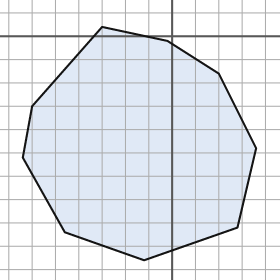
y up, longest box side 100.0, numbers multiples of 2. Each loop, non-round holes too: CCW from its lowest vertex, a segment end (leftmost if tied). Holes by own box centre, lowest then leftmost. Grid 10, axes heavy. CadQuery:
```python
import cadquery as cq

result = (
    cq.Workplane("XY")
    .moveTo(-12.0, -96.0)
    .lineTo(28.0, -82.0)
    .lineTo(36.0, -48.0)
    .lineTo(20.0, -16.0)
    .lineTo(-2.0, -2.0)
    .lineTo(-30.0, 4.0)
    .lineTo(-60.0, -30.0)
    .lineTo(-64.0, -52.0)
    .lineTo(-46.0, -84.0)
    .close()
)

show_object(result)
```